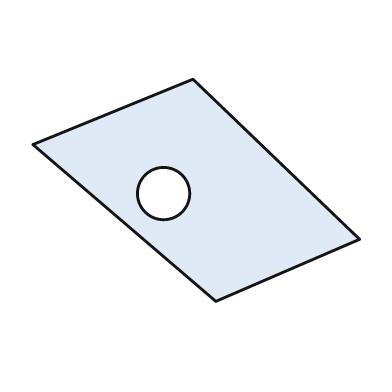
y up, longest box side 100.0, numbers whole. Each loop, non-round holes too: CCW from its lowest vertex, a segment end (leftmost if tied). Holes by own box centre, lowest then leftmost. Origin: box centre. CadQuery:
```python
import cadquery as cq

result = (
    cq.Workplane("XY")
    .moveTo(6.0, -34.0)
    .lineTo(50.0, -15.0)
    .lineTo(-1.0, 34.0)
    .lineTo(-50.0, 14.0)
    .close()
    .moveTo(-10.0, -1.0)
    .circle(8.0)
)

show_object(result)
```